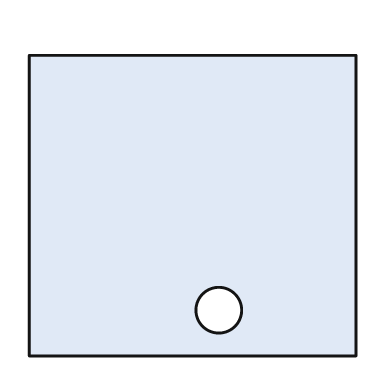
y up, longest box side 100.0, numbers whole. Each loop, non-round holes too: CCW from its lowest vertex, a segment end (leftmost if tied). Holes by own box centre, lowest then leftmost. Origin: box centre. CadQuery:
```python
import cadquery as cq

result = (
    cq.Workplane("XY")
    .moveTo(-50.0, -46.0)
    .lineTo(50.0, -46.0)
    .lineTo(50.0, 46.0)
    .lineTo(-50.0, 46.0)
    .close()
    .moveTo(8.0, -32.0)
    .circle(7.0)
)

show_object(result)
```